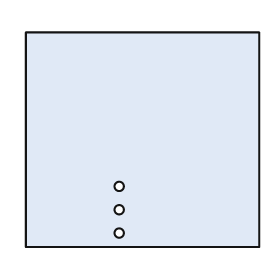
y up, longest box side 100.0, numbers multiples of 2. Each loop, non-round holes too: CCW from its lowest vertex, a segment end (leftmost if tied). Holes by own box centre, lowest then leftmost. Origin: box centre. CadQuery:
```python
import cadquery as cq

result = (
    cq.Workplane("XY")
    .moveTo(-50.0, -46.0)
    .lineTo(50.0, -46.0)
    .lineTo(50.0, 46.0)
    .lineTo(-50.0, 46.0)
    .close()
    .moveTo(-10.0, -40.0)
    .circle(2.0)
    .moveTo(-10.0, -30.0)
    .circle(2.0)
    .moveTo(-10.0, -20.0)
    .circle(2.0)
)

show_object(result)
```